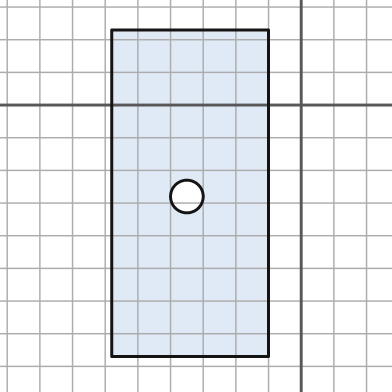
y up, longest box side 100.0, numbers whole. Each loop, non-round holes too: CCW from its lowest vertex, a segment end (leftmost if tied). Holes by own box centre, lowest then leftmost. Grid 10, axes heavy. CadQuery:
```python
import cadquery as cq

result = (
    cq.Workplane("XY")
    .moveTo(-58.0, -77.0)
    .lineTo(-10.0, -77.0)
    .lineTo(-10.0, 23.0)
    .lineTo(-58.0, 23.0)
    .close()
    .moveTo(-35.0, -28.0)
    .circle(5.0)
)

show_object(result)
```